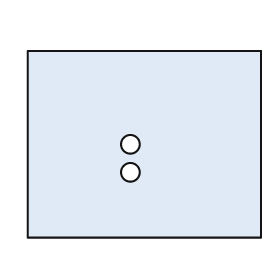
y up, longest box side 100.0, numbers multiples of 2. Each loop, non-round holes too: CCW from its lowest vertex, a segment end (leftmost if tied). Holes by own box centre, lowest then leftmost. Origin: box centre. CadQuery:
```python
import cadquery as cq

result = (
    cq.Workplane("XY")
    .moveTo(-50.0, -40.0)
    .lineTo(50.0, -40.0)
    .lineTo(50.0, 40.0)
    .lineTo(-50.0, 40.0)
    .close()
    .moveTo(-6.0, -12.0)
    .circle(4.0)
    .moveTo(-6.0, 0.0)
    .circle(4.0)
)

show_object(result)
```